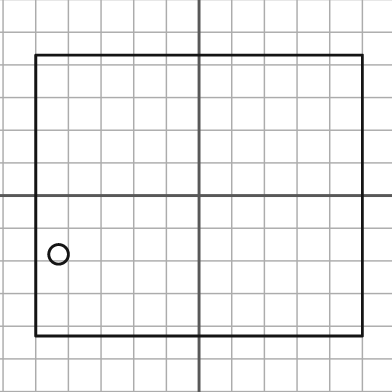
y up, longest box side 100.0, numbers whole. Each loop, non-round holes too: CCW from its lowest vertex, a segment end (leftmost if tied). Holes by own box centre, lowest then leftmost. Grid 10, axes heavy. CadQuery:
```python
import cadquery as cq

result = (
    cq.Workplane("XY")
    .moveTo(-50.0, -43.0)
    .lineTo(50.0, -43.0)
    .lineTo(50.0, 43.0)
    .lineTo(-50.0, 43.0)
    .close()
    .moveTo(-43.0, -18.0)
    .circle(3.0)
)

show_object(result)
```